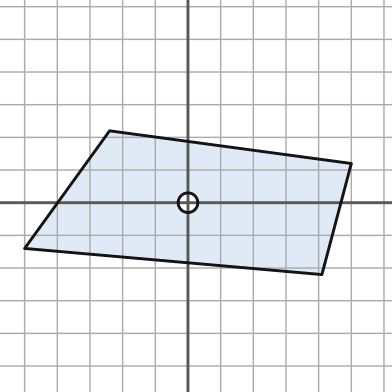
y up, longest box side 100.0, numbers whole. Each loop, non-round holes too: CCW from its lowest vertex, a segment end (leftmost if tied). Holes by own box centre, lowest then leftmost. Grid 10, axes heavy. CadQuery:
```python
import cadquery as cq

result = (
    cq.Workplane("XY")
    .moveTo(41.0, -22.0)
    .lineTo(50.0, 12.0)
    .lineTo(-24.0, 22.0)
    .lineTo(-50.0, -14.0)
    .close()
    .moveTo(0.0, 0.0)
    .circle(3.0)
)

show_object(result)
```